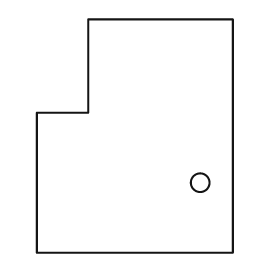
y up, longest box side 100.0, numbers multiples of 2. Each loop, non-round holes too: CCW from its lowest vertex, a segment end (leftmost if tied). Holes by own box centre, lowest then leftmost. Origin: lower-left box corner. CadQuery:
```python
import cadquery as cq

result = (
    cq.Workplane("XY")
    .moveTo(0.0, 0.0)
    .lineTo(84.0, 0.0)
    .lineTo(84.0, 100.0)
    .lineTo(22.0, 100.0)
    .lineTo(22.0, 60.0)
    .lineTo(0.0, 60.0)
    .close()
    .moveTo(70.0, 30.0)
    .circle(4.0)
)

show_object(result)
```